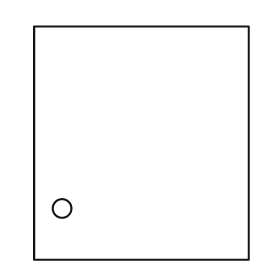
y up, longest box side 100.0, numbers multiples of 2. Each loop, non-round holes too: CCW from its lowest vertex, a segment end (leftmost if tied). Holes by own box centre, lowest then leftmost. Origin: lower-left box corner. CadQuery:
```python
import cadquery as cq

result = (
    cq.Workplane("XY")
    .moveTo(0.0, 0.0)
    .lineTo(92.0, 0.0)
    .lineTo(92.0, 100.0)
    .lineTo(0.0, 100.0)
    .close()
    .moveTo(12.0, 22.0)
    .circle(4.0)
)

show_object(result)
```